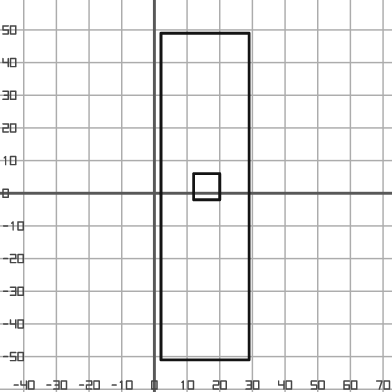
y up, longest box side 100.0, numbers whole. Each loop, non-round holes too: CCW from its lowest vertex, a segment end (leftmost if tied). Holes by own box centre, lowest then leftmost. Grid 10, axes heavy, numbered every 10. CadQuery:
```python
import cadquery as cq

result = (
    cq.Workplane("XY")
    .moveTo(2.0, -51.0)
    .lineTo(29.0, -51.0)
    .lineTo(29.0, 49.0)
    .lineTo(2.0, 49.0)
    .close()
    .moveTo(12.0, -2.0)
    .lineTo(20.0, -2.0)
    .lineTo(20.0, 6.0)
    .lineTo(12.0, 6.0)
    .close()
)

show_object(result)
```